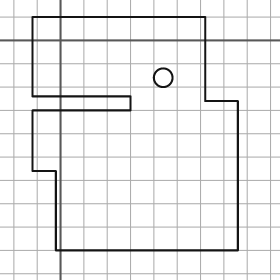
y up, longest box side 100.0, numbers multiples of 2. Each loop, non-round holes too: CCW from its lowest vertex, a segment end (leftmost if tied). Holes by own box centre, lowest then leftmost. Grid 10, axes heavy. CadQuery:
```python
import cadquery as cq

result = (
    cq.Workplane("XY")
    .moveTo(-2.0, -90.0)
    .lineTo(76.0, -90.0)
    .lineTo(76.0, -26.0)
    .lineTo(62.0, -26.0)
    .lineTo(62.0, 10.0)
    .lineTo(-12.0, 10.0)
    .lineTo(-12.0, -24.0)
    .lineTo(30.0, -24.0)
    .lineTo(30.0, -30.0)
    .lineTo(-12.0, -30.0)
    .lineTo(-12.0, -56.0)
    .lineTo(-2.0, -56.0)
    .close()
    .moveTo(44.0, -16.0)
    .circle(4.0)
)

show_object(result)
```